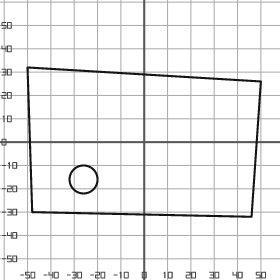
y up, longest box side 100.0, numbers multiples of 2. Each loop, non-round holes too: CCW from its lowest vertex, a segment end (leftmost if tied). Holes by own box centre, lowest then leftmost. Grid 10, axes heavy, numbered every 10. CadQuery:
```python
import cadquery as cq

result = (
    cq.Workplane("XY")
    .moveTo(46.0, -32.0)
    .lineTo(50.0, 26.0)
    .lineTo(-50.0, 32.0)
    .lineTo(-48.0, -30.0)
    .close()
    .moveTo(-26.0, -16.0)
    .circle(6.0)
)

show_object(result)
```